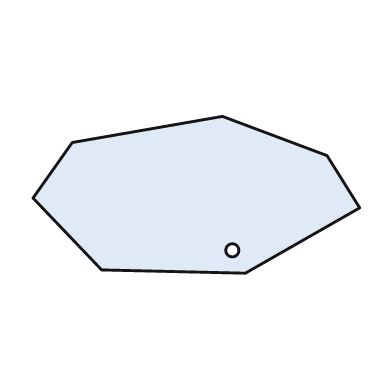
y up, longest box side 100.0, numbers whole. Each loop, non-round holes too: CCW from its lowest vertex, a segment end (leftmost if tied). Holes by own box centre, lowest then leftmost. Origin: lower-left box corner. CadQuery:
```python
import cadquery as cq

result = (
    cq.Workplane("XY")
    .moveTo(65.0, 0.0)
    .lineTo(100.0, 20.0)
    .lineTo(90.0, 36.0)
    .lineTo(58.0, 48.0)
    .lineTo(12.0, 40.0)
    .lineTo(0.0, 23.0)
    .lineTo(21.0, 1.0)
    .close()
    .moveTo(61.0, 7.0)
    .circle(2.0)
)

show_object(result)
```